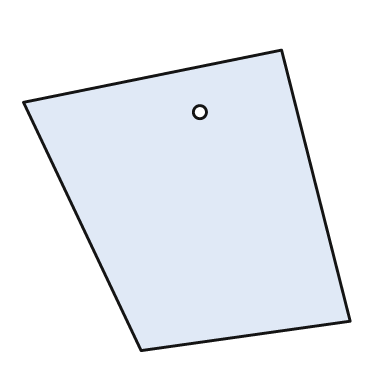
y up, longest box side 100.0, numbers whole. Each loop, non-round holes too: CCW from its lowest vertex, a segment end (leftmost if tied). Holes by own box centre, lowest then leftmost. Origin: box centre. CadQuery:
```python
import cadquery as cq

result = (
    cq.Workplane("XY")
    .moveTo(-14.0, -46.0)
    .lineTo(50.0, -37.0)
    .lineTo(29.0, 46.0)
    .lineTo(-50.0, 30.0)
    .close()
    .moveTo(4.0, 27.0)
    .circle(2.0)
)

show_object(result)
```